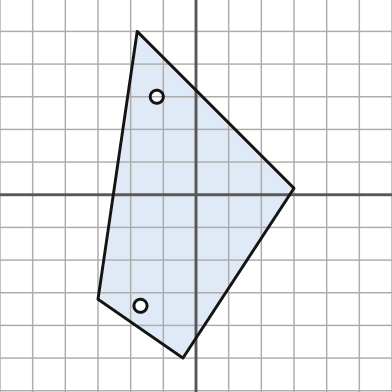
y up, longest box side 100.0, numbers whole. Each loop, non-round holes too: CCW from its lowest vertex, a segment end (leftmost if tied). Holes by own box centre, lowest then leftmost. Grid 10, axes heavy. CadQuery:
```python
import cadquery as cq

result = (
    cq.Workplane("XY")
    .moveTo(-4.0, -50.0)
    .lineTo(30.0, 2.0)
    .lineTo(-18.0, 50.0)
    .lineTo(-30.0, -32.0)
    .close()
    .moveTo(-17.0, -34.0)
    .circle(2.0)
    .moveTo(-12.0, 30.0)
    .circle(2.0)
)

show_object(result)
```